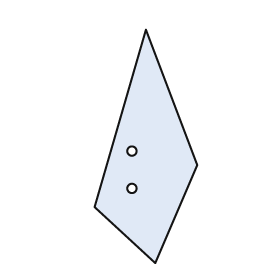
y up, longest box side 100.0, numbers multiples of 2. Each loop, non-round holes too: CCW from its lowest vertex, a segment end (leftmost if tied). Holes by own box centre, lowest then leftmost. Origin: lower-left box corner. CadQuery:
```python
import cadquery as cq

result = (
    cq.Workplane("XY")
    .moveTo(26.0, 0.0)
    .lineTo(44.0, 42.0)
    .lineTo(22.0, 100.0)
    .lineTo(0.0, 24.0)
    .close()
    .moveTo(16.0, 32.0)
    .circle(2.0)
    .moveTo(16.0, 48.0)
    .circle(2.0)
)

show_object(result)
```